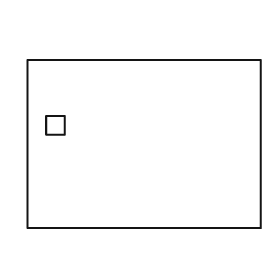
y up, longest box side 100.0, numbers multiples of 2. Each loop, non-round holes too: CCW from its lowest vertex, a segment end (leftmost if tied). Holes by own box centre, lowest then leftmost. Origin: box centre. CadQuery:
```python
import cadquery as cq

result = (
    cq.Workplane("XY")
    .moveTo(-50.0, -36.0)
    .lineTo(50.0, -36.0)
    .lineTo(50.0, 36.0)
    .lineTo(-50.0, 36.0)
    .close()
    .moveTo(-42.0, 4.0)
    .lineTo(-34.0, 4.0)
    .lineTo(-34.0, 12.0)
    .lineTo(-42.0, 12.0)
    .close()
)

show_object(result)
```